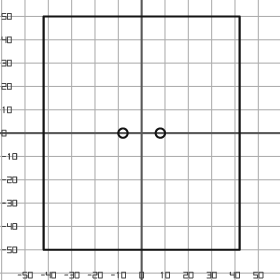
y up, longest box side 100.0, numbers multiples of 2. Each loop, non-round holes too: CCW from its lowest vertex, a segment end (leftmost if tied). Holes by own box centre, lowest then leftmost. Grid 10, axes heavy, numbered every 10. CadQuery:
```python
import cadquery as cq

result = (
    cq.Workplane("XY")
    .moveTo(-42.0, -50.0)
    .lineTo(42.0, -50.0)
    .lineTo(42.0, 50.0)
    .lineTo(-42.0, 50.0)
    .close()
    .moveTo(-8.0, 0.0)
    .circle(2.0)
    .moveTo(8.0, 0.0)
    .circle(2.0)
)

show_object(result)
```